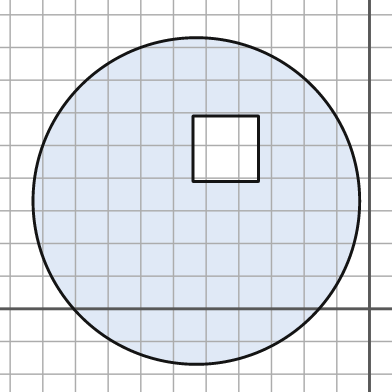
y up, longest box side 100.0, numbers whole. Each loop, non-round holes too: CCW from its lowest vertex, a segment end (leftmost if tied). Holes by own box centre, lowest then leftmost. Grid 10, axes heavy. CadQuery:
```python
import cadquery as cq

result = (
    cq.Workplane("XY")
    .moveTo(-53.0, 33.0)
    .circle(50.0)
    .moveTo(-54.0, 39.0)
    .lineTo(-34.0, 39.0)
    .lineTo(-34.0, 59.0)
    .lineTo(-54.0, 59.0)
    .close()
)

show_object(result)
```